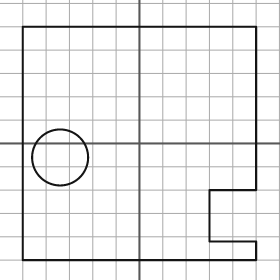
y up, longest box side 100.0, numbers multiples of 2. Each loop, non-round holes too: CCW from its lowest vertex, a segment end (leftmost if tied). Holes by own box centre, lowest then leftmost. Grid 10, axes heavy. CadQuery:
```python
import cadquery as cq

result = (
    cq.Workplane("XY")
    .moveTo(-50.0, -50.0)
    .lineTo(50.0, -50.0)
    .lineTo(50.0, -42.0)
    .lineTo(30.0, -42.0)
    .lineTo(30.0, -20.0)
    .lineTo(50.0, -20.0)
    .lineTo(50.0, 50.0)
    .lineTo(-50.0, 50.0)
    .close()
    .moveTo(-34.0, -6.0)
    .circle(12.0)
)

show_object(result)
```